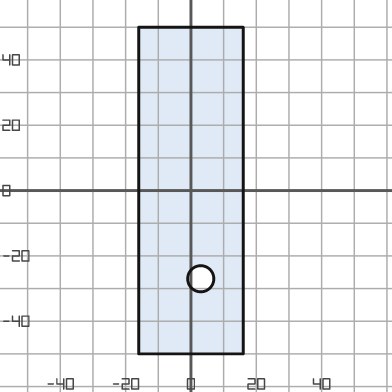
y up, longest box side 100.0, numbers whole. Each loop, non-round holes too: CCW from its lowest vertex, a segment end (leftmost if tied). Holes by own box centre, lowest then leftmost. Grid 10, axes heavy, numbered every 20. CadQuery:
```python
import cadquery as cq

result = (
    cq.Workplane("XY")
    .moveTo(-16.0, -50.0)
    .lineTo(16.0, -50.0)
    .lineTo(16.0, 50.0)
    .lineTo(-16.0, 50.0)
    .close()
    .moveTo(3.0, -27.0)
    .circle(4.0)
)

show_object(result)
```